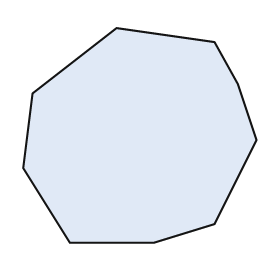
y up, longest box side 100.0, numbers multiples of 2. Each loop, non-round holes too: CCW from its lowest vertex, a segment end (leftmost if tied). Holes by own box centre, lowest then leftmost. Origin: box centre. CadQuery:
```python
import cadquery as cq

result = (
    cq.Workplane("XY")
    .moveTo(-30.0, -46.0)
    .lineTo(6.0, -46.0)
    .lineTo(32.0, -38.0)
    .lineTo(50.0, -2.0)
    .lineTo(42.0, 22.0)
    .lineTo(32.0, 40.0)
    .lineTo(-10.0, 46.0)
    .lineTo(-46.0, 18.0)
    .lineTo(-50.0, -14.0)
    .close()
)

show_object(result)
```